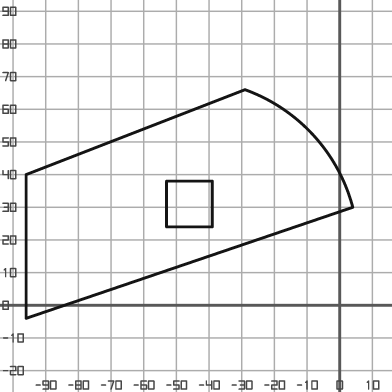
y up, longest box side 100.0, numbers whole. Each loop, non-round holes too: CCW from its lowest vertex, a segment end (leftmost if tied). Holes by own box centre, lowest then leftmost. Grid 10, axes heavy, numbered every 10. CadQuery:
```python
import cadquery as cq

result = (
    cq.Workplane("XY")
    .moveTo(-96.0, -4.0)
    .lineTo(4.0, 30.0)
    .threePointArc((-8.0, 52.0), (-29.0, 66.0))
    .lineTo(-96.0, 40.0)
    .close()
    .moveTo(-53.0, 24.0)
    .lineTo(-39.0, 24.0)
    .lineTo(-39.0, 38.0)
    .lineTo(-53.0, 38.0)
    .close()
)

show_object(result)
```